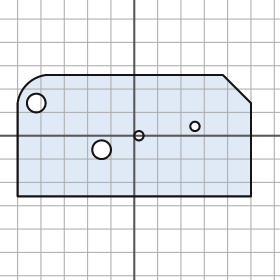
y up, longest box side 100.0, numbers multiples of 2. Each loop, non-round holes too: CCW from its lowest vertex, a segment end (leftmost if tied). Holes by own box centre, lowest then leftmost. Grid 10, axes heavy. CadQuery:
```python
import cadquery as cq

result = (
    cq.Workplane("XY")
    .moveTo(-50.0, -26.0)
    .lineTo(50.0, -26.0)
    .lineTo(50.0, 14.0)
    .lineTo(38.0, 26.0)
    .lineTo(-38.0, 26.0)
    .threePointArc((-46.0, 22.0), (-50.0, 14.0))
    .close()
    .moveTo(-14.0, -6.0)
    .circle(4.0)
    .moveTo(2.0, 0.0)
    .circle(2.0)
    .moveTo(26.0, 4.0)
    .circle(2.0)
    .moveTo(-42.0, 14.0)
    .circle(4.0)
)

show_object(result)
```